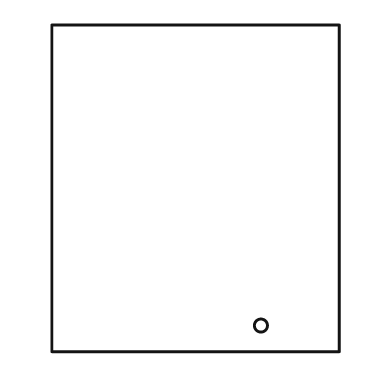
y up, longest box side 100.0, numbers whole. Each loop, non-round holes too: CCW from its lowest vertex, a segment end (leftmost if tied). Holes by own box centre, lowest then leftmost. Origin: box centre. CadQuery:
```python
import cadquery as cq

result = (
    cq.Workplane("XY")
    .moveTo(-44.0, -50.0)
    .lineTo(44.0, -50.0)
    .lineTo(44.0, 50.0)
    .lineTo(-44.0, 50.0)
    .close()
    .moveTo(20.0, -42.0)
    .circle(2.0)
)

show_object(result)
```